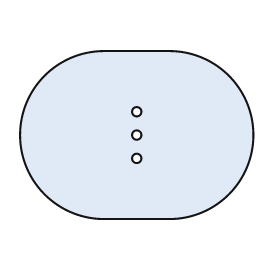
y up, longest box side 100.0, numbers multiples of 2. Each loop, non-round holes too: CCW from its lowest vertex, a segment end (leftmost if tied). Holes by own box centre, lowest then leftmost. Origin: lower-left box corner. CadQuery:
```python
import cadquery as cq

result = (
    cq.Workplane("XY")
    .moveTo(36.0, 0.0)
    .lineTo(64.0, 0.0)
    .threePointArc((100.0, 36.0), (64.0, 72.0))
    .lineTo(36.0, 72.0)
    .threePointArc((0.0, 36.0), (36.0, 0.0))
    .close()
    .moveTo(50.0, 26.0)
    .circle(2.0)
    .moveTo(50.0, 36.0)
    .circle(2.0)
    .moveTo(50.0, 46.0)
    .circle(2.0)
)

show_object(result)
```